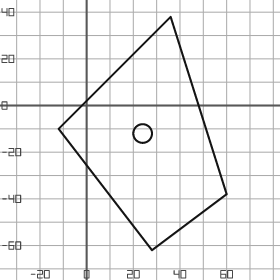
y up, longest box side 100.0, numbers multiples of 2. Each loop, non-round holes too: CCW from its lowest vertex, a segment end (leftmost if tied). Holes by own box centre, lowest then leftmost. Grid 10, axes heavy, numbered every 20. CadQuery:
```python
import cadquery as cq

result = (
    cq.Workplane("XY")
    .moveTo(28.0, -62.0)
    .lineTo(60.0, -38.0)
    .lineTo(36.0, 38.0)
    .lineTo(-12.0, -10.0)
    .close()
    .moveTo(24.0, -12.0)
    .circle(4.0)
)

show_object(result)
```